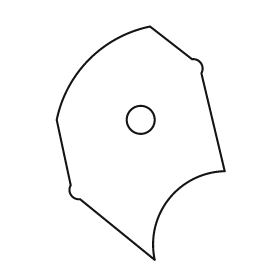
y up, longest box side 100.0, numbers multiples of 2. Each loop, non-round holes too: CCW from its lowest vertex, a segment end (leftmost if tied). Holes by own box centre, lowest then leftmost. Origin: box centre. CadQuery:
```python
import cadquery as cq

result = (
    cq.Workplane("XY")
    .moveTo(6.0, -50.0)
    .threePointArc((12.0, -24.0), (36.0, -12.0))
    .lineTo(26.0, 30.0)
    .threePointArc((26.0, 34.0), (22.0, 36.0))
    .lineTo(4.0, 50.0)
    .threePointArc((-22.0, 36.0), (-36.0, 10.0))
    .lineTo(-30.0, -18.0)
    .threePointArc((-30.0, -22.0), (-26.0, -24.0))
    .close()
    .moveTo(0.0, 10.0)
    .circle(6.0)
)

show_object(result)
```